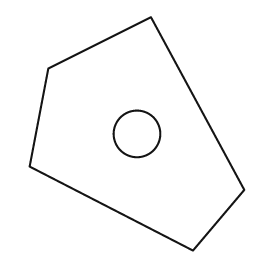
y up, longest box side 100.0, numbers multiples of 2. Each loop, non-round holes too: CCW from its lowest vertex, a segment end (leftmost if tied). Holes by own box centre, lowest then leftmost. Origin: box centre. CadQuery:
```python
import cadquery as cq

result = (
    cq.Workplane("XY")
    .moveTo(24.0, -50.0)
    .lineTo(46.0, -24.0)
    .lineTo(6.0, 50.0)
    .lineTo(-38.0, 28.0)
    .lineTo(-46.0, -14.0)
    .close()
    .moveTo(0.0, 0.0)
    .circle(10.0)
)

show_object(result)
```